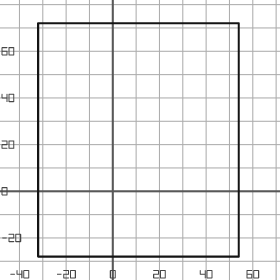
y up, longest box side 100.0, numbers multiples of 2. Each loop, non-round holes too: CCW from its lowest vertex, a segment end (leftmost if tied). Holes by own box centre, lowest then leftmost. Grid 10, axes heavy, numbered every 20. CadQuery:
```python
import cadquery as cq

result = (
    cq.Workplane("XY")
    .moveTo(-32.0, -28.0)
    .lineTo(54.0, -28.0)
    .lineTo(54.0, 72.0)
    .lineTo(-32.0, 72.0)
    .close()
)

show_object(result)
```